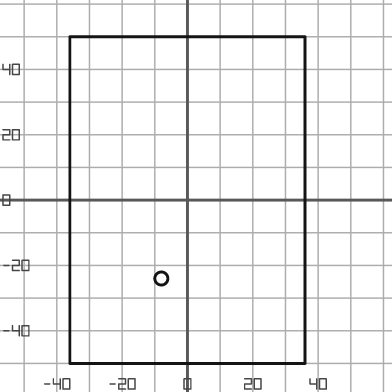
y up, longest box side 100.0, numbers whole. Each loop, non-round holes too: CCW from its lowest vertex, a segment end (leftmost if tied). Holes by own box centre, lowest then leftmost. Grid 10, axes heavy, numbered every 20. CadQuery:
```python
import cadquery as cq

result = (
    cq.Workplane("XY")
    .moveTo(-36.0, -50.0)
    .lineTo(36.0, -50.0)
    .lineTo(36.0, 50.0)
    .lineTo(-36.0, 50.0)
    .close()
    .moveTo(-8.0, -24.0)
    .circle(2.0)
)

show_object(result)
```